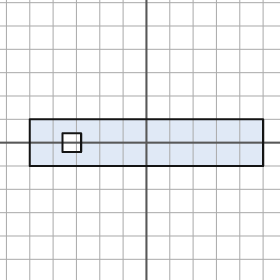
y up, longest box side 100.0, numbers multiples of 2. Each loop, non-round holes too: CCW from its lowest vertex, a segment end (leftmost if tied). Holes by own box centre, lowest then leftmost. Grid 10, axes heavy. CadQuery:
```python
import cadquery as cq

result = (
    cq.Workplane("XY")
    .moveTo(-50.0, -10.0)
    .lineTo(50.0, -10.0)
    .lineTo(50.0, 10.0)
    .lineTo(-50.0, 10.0)
    .close()
    .moveTo(-36.0, -4.0)
    .lineTo(-28.0, -4.0)
    .lineTo(-28.0, 4.0)
    .lineTo(-36.0, 4.0)
    .close()
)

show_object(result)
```